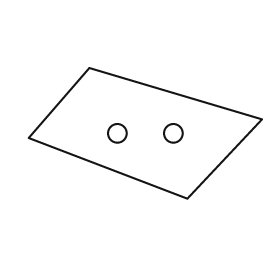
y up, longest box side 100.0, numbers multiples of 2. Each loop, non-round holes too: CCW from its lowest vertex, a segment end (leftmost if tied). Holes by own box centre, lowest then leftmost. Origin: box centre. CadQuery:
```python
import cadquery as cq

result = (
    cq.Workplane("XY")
    .moveTo(18.0, -28.0)
    .lineTo(50.0, 6.0)
    .lineTo(-24.0, 28.0)
    .lineTo(-50.0, -2.0)
    .close()
    .moveTo(-12.0, 0.0)
    .circle(4.0)
    .moveTo(12.0, 0.0)
    .circle(4.0)
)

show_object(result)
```